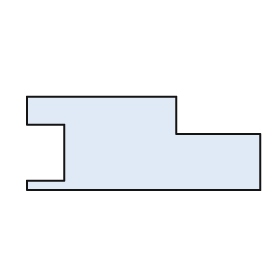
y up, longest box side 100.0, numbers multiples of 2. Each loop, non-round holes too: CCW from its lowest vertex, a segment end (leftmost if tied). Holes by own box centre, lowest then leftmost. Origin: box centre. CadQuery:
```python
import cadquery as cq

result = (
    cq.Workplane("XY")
    .moveTo(-50.0, -20.0)
    .lineTo(50.0, -20.0)
    .lineTo(50.0, 4.0)
    .lineTo(14.0, 4.0)
    .lineTo(14.0, 20.0)
    .lineTo(-50.0, 20.0)
    .lineTo(-50.0, 8.0)
    .lineTo(-34.0, 8.0)
    .lineTo(-34.0, -16.0)
    .lineTo(-50.0, -16.0)
    .close()
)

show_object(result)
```